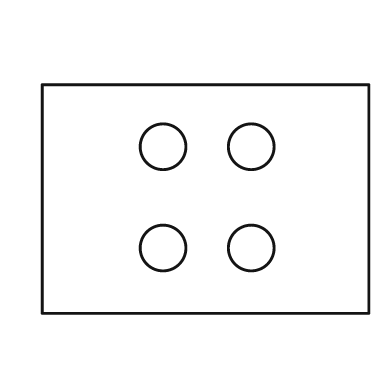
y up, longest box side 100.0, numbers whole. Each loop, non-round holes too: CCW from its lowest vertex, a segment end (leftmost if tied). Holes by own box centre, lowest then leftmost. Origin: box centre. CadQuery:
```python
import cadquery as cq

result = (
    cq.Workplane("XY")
    .moveTo(-50.0, -35.0)
    .lineTo(50.0, -35.0)
    .lineTo(50.0, 35.0)
    .lineTo(-50.0, 35.0)
    .close()
    .moveTo(-13.0, -15.0)
    .circle(7.0)
    .moveTo(14.0, -15.0)
    .circle(7.0)
    .moveTo(-13.0, 16.0)
    .circle(7.0)
    .moveTo(14.0, 16.0)
    .circle(7.0)
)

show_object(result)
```